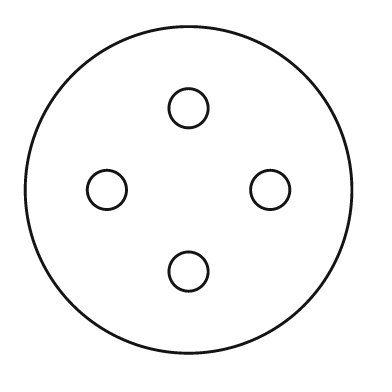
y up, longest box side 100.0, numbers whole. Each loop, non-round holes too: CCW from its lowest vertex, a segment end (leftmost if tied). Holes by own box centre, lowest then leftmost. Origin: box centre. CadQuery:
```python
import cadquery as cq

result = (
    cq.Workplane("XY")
    .moveTo(0.0, 0.0)
    .circle(50.0)
    .moveTo(0.0, -25.0)
    .circle(6.0)
    .moveTo(-25.0, 0.0)
    .circle(6.0)
    .moveTo(25.0, 0.0)
    .circle(6.0)
    .moveTo(0.0, 25.0)
    .circle(6.0)
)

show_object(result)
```